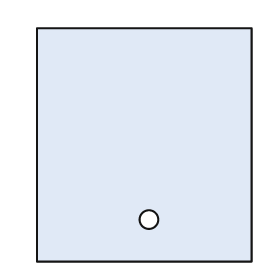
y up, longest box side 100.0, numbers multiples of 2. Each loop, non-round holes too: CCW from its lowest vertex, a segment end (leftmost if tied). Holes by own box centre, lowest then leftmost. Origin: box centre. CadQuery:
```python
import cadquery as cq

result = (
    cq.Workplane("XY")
    .moveTo(-46.0, -50.0)
    .lineTo(46.0, -50.0)
    .lineTo(46.0, 50.0)
    .lineTo(-46.0, 50.0)
    .close()
    .moveTo(2.0, -32.0)
    .circle(4.0)
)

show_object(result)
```